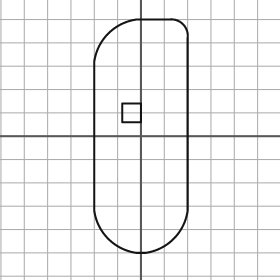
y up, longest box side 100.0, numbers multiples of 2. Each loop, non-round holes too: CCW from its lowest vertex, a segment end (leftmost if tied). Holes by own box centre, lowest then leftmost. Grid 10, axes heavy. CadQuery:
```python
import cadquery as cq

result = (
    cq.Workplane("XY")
    .moveTo(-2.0, -50.0)
    .lineTo(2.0, -50.0)
    .threePointArc((14.0, -44.0), (20.0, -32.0))
    .lineTo(20.0, 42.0)
    .threePointArc((18.0, 48.0), (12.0, 50.0))
    .lineTo(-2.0, 50.0)
    .threePointArc((-14.0, 44.0), (-20.0, 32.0))
    .lineTo(-20.0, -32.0)
    .threePointArc((-14.0, -44.0), (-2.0, -50.0))
    .close()
    .moveTo(-8.0, 6.0)
    .lineTo(0.0, 6.0)
    .lineTo(0.0, 14.0)
    .lineTo(-8.0, 14.0)
    .close()
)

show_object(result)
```